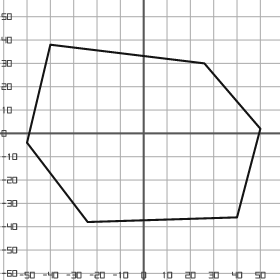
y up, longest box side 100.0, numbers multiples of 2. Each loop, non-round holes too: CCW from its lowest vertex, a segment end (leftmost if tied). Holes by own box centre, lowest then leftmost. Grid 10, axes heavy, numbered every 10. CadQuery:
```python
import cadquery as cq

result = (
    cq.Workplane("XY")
    .moveTo(-24.0, -38.0)
    .lineTo(40.0, -36.0)
    .lineTo(50.0, 2.0)
    .lineTo(26.0, 30.0)
    .lineTo(-40.0, 38.0)
    .lineTo(-50.0, -4.0)
    .close()
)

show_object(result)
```